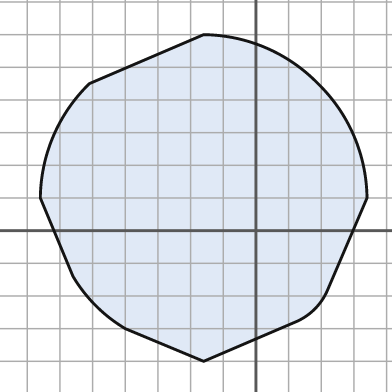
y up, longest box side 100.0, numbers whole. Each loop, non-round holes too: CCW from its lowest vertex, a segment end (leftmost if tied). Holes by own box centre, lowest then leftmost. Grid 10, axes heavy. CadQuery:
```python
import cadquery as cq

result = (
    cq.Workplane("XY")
    .moveTo(-16.0, -40.0)
    .lineTo(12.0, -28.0)
    .threePointArc((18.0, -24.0), (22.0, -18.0))
    .lineTo(34.0, 10.0)
    .threePointArc((30.0, 29.0), (19.0, 45.0))
    .threePointArc((3.0, 56.0), (-16.0, 60.0))
    .lineTo(-51.0, 45.0)
    .threePointArc((-62.0, 29.0), (-66.0, 10.0))
    .lineTo(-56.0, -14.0)
    .threePointArc((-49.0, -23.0), (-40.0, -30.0))
    .close()
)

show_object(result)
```